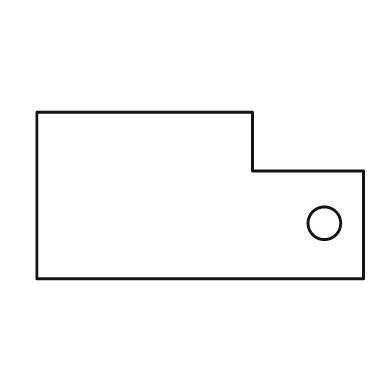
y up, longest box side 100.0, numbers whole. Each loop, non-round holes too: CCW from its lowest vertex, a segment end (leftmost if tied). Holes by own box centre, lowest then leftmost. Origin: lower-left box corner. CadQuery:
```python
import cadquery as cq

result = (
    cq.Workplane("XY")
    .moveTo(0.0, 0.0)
    .lineTo(100.0, 0.0)
    .lineTo(100.0, 33.0)
    .lineTo(66.0, 33.0)
    .lineTo(66.0, 51.0)
    .lineTo(0.0, 51.0)
    .close()
    .moveTo(88.0, 17.0)
    .circle(5.0)
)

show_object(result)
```